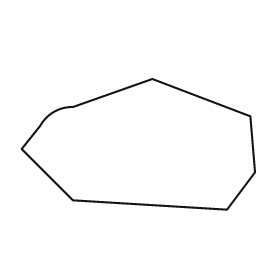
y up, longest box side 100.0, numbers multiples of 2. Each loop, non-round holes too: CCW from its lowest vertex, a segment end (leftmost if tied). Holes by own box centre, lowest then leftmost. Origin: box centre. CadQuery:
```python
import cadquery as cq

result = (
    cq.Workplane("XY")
    .moveTo(38.0, -28.0)
    .lineTo(50.0, -12.0)
    .lineTo(48.0, 12.0)
    .lineTo(6.0, 28.0)
    .lineTo(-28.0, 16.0)
    .threePointArc((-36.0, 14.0), (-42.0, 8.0))
    .lineTo(-50.0, -2.0)
    .lineTo(-28.0, -24.0)
    .close()
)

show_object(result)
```